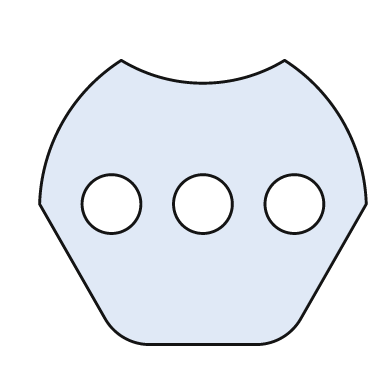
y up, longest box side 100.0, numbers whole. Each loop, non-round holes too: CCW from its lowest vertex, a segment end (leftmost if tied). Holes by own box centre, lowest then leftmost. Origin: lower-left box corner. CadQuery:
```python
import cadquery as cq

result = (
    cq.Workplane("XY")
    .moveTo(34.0, 0.0)
    .lineTo(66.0, 0.0)
    .threePointArc((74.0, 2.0), (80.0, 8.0))
    .lineTo(100.0, 43.0)
    .threePointArc((93.0, 68.0), (75.0, 87.0))
    .threePointArc((50.0, 80.0), (25.0, 87.0))
    .threePointArc((7.0, 68.0), (0.0, 43.0))
    .lineTo(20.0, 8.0)
    .threePointArc((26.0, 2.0), (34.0, 0.0))
    .close()
    .moveTo(22.0, 43.0)
    .circle(9.0)
    .moveTo(50.0, 43.0)
    .circle(9.0)
    .moveTo(78.0, 43.0)
    .circle(9.0)
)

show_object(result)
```